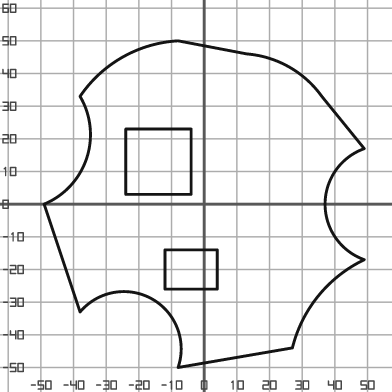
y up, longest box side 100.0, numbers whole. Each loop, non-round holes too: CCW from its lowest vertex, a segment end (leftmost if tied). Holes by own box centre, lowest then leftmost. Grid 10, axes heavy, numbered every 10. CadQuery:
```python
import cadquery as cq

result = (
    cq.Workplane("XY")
    .moveTo(-8.0, -50.0)
    .lineTo(27.0, -44.0)
    .threePointArc((35.0, -28.0), (49.0, -17.0))
    .threePointArc((37.0, 0.0), (49.0, 17.0))
    .lineTo(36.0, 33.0)
    .threePointArc((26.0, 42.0), (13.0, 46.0))
    .lineTo(-8.0, 50.0)
    .threePointArc((-25.0, 45.0), (-38.0, 33.0))
    .threePointArc((-36.0, 14.0), (-49.0, 0.0))
    .lineTo(-38.0, -33.0)
    .threePointArc((-16.0, -29.0), (-8.0, -50.0))
    .close()
    .moveTo(-12.0, -26.0)
    .lineTo(4.0, -26.0)
    .lineTo(4.0, -14.0)
    .lineTo(-12.0, -14.0)
    .close()
    .moveTo(-24.0, 3.0)
    .lineTo(-4.0, 3.0)
    .lineTo(-4.0, 23.0)
    .lineTo(-24.0, 23.0)
    .close()
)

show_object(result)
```